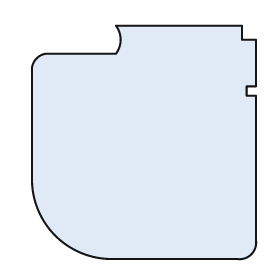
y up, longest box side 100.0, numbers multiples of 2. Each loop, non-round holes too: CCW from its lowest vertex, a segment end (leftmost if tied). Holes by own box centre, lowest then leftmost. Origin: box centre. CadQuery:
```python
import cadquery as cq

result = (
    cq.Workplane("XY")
    .moveTo(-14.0, -50.0)
    .lineTo(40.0, -50.0)
    .threePointArc((46.0, -48.0), (48.0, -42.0))
    .lineTo(48.0, 20.0)
    .lineTo(44.0, 20.0)
    .lineTo(44.0, 24.0)
    .lineTo(48.0, 24.0)
    .lineTo(48.0, 44.0)
    .lineTo(42.0, 44.0)
    .lineTo(42.0, 50.0)
    .lineTo(-12.0, 50.0)
    .threePointArc((-10.0, 44.0), (-12.0, 38.0))
    .lineTo(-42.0, 38.0)
    .threePointArc((-46.0, 36.0), (-48.0, 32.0))
    .lineTo(-48.0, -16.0)
    .threePointArc((-38.0, -40.0), (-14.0, -50.0))
    .close()
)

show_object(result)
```